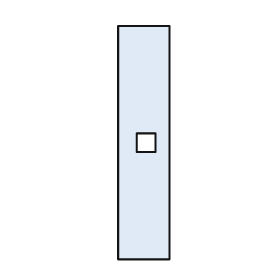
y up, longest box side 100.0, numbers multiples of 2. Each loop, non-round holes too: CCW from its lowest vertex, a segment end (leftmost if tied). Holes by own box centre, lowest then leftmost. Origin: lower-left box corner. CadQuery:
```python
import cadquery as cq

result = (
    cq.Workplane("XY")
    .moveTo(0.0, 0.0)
    .lineTo(22.0, 0.0)
    .lineTo(22.0, 100.0)
    .lineTo(0.0, 100.0)
    .close()
    .moveTo(8.0, 46.0)
    .lineTo(16.0, 46.0)
    .lineTo(16.0, 54.0)
    .lineTo(8.0, 54.0)
    .close()
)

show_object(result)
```